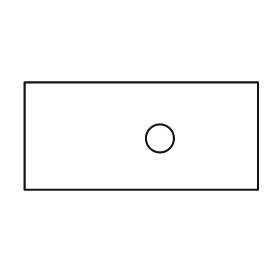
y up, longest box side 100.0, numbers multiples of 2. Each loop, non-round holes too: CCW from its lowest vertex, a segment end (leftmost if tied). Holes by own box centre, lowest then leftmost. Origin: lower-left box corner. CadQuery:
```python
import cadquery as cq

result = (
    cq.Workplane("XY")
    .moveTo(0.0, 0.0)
    .lineTo(100.0, 0.0)
    .lineTo(100.0, 46.0)
    .lineTo(0.0, 46.0)
    .close()
    .moveTo(58.0, 22.0)
    .circle(6.0)
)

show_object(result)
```